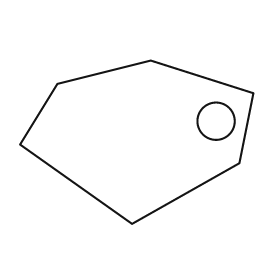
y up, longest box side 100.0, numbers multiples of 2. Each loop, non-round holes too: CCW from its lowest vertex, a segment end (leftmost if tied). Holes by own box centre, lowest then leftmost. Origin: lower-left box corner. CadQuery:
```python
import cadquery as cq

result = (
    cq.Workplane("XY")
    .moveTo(48.0, 0.0)
    .lineTo(94.0, 26.0)
    .lineTo(100.0, 56.0)
    .lineTo(56.0, 70.0)
    .lineTo(16.0, 60.0)
    .lineTo(0.0, 34.0)
    .close()
    .moveTo(84.0, 44.0)
    .circle(8.0)
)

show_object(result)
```